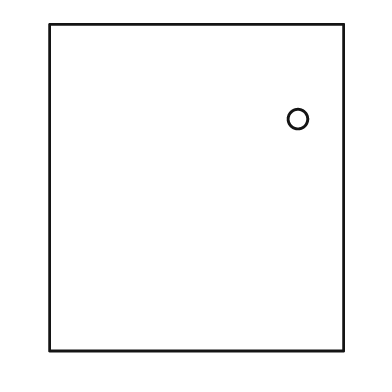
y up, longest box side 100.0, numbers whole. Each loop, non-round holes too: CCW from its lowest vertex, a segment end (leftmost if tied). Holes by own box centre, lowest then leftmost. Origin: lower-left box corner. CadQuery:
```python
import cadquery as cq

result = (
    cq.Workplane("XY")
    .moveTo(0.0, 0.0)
    .lineTo(90.0, 0.0)
    .lineTo(90.0, 100.0)
    .lineTo(0.0, 100.0)
    .close()
    .moveTo(76.0, 71.0)
    .circle(3.0)
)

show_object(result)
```